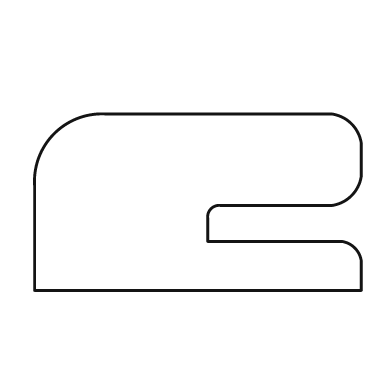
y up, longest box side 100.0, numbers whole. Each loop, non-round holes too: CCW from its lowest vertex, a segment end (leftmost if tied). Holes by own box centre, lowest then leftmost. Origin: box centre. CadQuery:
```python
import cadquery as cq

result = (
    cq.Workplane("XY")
    .moveTo(-50.0, -27.0)
    .lineTo(50.0, -27.0)
    .lineTo(50.0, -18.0)
    .threePointArc((48.0, -14.0), (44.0, -12.0))
    .lineTo(3.0, -12.0)
    .lineTo(3.0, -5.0)
    .threePointArc((4.0, -2.0), (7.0, -1.0))
    .lineTo(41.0, -1.0)
    .threePointArc((47.0, 2.0), (50.0, 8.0))
    .lineTo(50.0, 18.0)
    .threePointArc((47.0, 24.0), (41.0, 27.0))
    .lineTo(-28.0, 27.0)
    .threePointArc((-44.0, 21.0), (-50.0, 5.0))
    .close()
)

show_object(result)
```